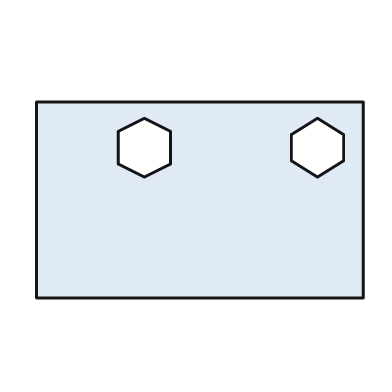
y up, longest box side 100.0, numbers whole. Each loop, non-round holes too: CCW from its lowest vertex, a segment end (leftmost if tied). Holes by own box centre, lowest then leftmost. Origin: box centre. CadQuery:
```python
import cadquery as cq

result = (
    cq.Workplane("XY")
    .moveTo(-50.0, -30.0)
    .lineTo(50.0, -30.0)
    .lineTo(50.0, 30.0)
    .lineTo(-50.0, 30.0)
    .close()
    .moveTo(-17.0, 7.0)
    .lineTo(-9.0, 11.0)
    .lineTo(-9.0, 21.0)
    .lineTo(-17.0, 25.0)
    .lineTo(-25.0, 21.0)
    .lineTo(-25.0, 11.0)
    .close()
    .moveTo(36.0, 7.0)
    .lineTo(44.0, 12.0)
    .lineTo(44.0, 20.0)
    .lineTo(36.0, 25.0)
    .lineTo(28.0, 20.0)
    .lineTo(28.0, 12.0)
    .close()
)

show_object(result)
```